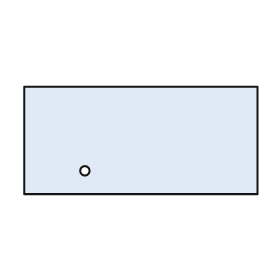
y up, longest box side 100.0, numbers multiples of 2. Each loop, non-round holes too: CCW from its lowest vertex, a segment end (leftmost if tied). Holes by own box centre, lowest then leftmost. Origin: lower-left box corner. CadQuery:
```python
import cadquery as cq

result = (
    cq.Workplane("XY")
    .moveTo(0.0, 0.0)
    .lineTo(100.0, 0.0)
    .lineTo(100.0, 46.0)
    .lineTo(0.0, 46.0)
    .close()
    .moveTo(26.0, 10.0)
    .circle(2.0)
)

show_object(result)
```